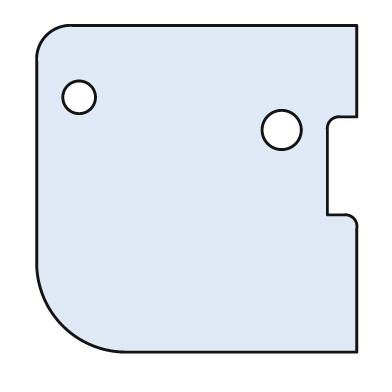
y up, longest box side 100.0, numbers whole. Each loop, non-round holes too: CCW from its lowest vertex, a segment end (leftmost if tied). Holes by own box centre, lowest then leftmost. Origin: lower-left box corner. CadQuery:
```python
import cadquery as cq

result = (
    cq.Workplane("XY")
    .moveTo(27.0, 0.0)
    .lineTo(98.0, 0.0)
    .lineTo(98.0, 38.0)
    .threePointArc((97.0, 41.0), (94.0, 42.0))
    .lineTo(89.0, 42.0)
    .lineTo(89.0, 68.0)
    .threePointArc((90.0, 71.0), (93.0, 72.0))
    .lineTo(98.0, 72.0)
    .lineTo(98.0, 100.0)
    .lineTo(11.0, 100.0)
    .threePointArc((3.0, 97.0), (0.0, 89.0))
    .lineTo(0.0, 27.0)
    .threePointArc((8.0, 8.0), (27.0, 0.0))
    .close()
    .moveTo(75.0, 68.0)
    .circle(6.0)
    .moveTo(13.0, 78.0)
    .circle(5.0)
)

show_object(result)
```